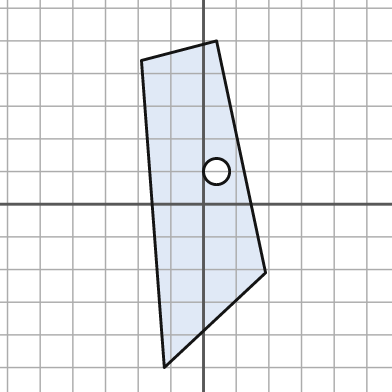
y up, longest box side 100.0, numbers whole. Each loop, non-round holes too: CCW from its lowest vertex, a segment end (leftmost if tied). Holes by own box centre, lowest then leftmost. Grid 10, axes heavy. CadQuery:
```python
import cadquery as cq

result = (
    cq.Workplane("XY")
    .moveTo(-12.0, -50.0)
    .lineTo(19.0, -21.0)
    .lineTo(4.0, 50.0)
    .lineTo(-19.0, 44.0)
    .close()
    .moveTo(4.0, 10.0)
    .circle(4.0)
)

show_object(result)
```